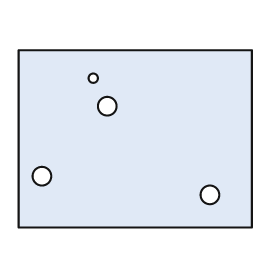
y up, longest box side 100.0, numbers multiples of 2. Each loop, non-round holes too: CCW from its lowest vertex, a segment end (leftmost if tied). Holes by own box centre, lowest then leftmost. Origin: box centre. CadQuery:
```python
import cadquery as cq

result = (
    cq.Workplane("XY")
    .moveTo(-50.0, -38.0)
    .lineTo(50.0, -38.0)
    .lineTo(50.0, 38.0)
    .lineTo(-50.0, 38.0)
    .close()
    .moveTo(32.0, -24.0)
    .circle(4.0)
    .moveTo(-40.0, -16.0)
    .circle(4.0)
    .moveTo(-12.0, 14.0)
    .circle(4.0)
    .moveTo(-18.0, 26.0)
    .circle(2.0)
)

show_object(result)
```